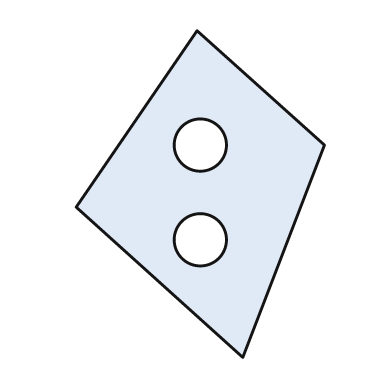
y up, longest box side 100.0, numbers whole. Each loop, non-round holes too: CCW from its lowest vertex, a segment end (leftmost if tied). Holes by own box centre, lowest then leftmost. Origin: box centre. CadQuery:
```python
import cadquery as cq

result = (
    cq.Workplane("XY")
    .moveTo(13.0, -50.0)
    .lineTo(38.0, 15.0)
    .lineTo(-1.0, 50.0)
    .lineTo(-38.0, -4.0)
    .close()
    .moveTo(0.0, -14.0)
    .circle(8.0)
    .moveTo(0.0, 15.0)
    .circle(8.0)
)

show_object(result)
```